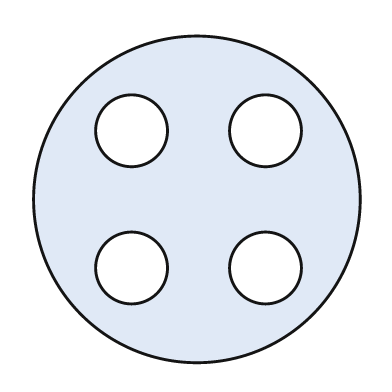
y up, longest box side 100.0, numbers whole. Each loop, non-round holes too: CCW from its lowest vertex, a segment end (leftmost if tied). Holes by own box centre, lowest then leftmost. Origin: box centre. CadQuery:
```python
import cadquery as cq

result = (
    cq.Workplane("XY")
    .moveTo(0.0, 0.0)
    .circle(50.0)
    .moveTo(-20.0, -21.0)
    .circle(11.0)
    .moveTo(21.0, -21.0)
    .circle(11.0)
    .moveTo(-20.0, 21.0)
    .circle(11.0)
    .moveTo(21.0, 21.0)
    .circle(11.0)
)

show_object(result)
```